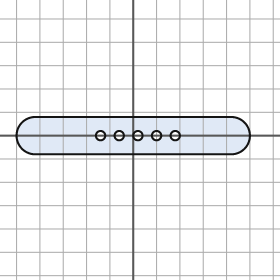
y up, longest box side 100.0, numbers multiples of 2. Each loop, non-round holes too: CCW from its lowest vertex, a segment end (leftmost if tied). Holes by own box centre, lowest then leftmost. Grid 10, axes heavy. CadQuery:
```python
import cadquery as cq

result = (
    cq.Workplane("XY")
    .moveTo(-42.0, -8.0)
    .lineTo(42.0, -8.0)
    .threePointArc((50.0, 0.0), (42.0, 8.0))
    .lineTo(-42.0, 8.0)
    .threePointArc((-50.0, 0.0), (-42.0, -8.0))
    .close()
    .moveTo(-14.0, 0.0)
    .circle(2.0)
    .moveTo(-6.0, 0.0)
    .circle(2.0)
    .moveTo(2.0, 0.0)
    .circle(2.0)
    .moveTo(10.0, 0.0)
    .circle(2.0)
    .moveTo(18.0, 0.0)
    .circle(2.0)
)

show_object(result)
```